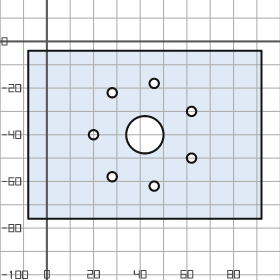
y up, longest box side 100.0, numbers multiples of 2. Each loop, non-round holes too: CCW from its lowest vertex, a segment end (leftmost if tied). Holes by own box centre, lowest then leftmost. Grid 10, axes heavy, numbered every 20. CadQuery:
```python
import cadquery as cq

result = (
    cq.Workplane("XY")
    .moveTo(-8.0, -76.0)
    .lineTo(92.0, -76.0)
    .lineTo(92.0, -4.0)
    .lineTo(-8.0, -4.0)
    .close()
    .moveTo(46.0, -62.0)
    .circle(2.0)
    .moveTo(28.0, -58.0)
    .circle(2.0)
    .moveTo(62.0, -50.0)
    .circle(2.0)
    .moveTo(20.0, -40.0)
    .circle(2.0)
    .moveTo(42.0, -40.0)
    .circle(8.0)
    .moveTo(62.0, -30.0)
    .circle(2.0)
    .moveTo(28.0, -22.0)
    .circle(2.0)
    .moveTo(46.0, -18.0)
    .circle(2.0)
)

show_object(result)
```